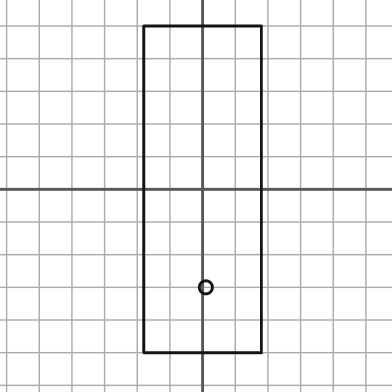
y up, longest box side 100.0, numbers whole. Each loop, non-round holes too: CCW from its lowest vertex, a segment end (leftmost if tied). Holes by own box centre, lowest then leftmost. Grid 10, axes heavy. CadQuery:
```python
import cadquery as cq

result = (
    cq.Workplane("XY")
    .moveTo(-18.0, -50.0)
    .lineTo(18.0, -50.0)
    .lineTo(18.0, 50.0)
    .lineTo(-18.0, 50.0)
    .close()
    .moveTo(1.0, -30.0)
    .circle(2.0)
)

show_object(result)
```